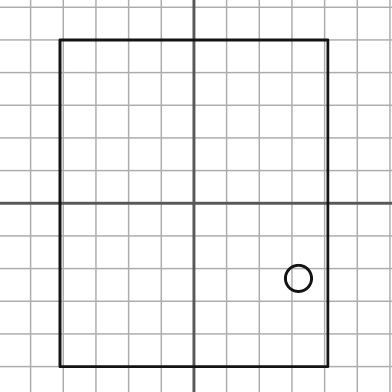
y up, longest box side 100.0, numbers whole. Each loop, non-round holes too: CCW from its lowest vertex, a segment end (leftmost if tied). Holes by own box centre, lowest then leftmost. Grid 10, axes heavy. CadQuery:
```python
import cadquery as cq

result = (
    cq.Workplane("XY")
    .moveTo(-41.0, -50.0)
    .lineTo(41.0, -50.0)
    .lineTo(41.0, 50.0)
    .lineTo(-41.0, 50.0)
    .close()
    .moveTo(32.0, -23.0)
    .circle(4.0)
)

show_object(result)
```